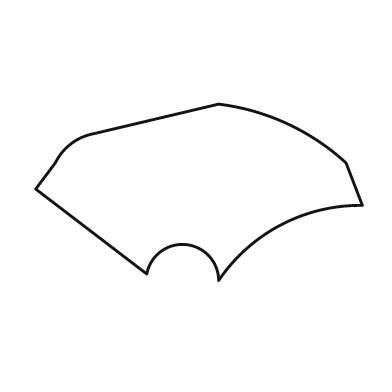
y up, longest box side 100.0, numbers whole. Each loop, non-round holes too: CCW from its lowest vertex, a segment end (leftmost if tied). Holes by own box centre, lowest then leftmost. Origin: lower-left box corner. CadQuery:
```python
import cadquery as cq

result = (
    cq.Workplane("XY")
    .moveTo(56.0, 0.0)
    .threePointArc((75.0, 17.0), (100.0, 23.0))
    .lineTo(95.0, 36.0)
    .threePointArc((77.0, 48.0), (56.0, 54.0))
    .lineTo(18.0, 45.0)
    .threePointArc((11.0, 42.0), (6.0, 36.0))
    .lineTo(0.0, 28.0)
    .lineTo(34.0, 2.0)
    .threePointArc((46.0, 11.0), (56.0, 0.0))
    .close()
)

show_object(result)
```